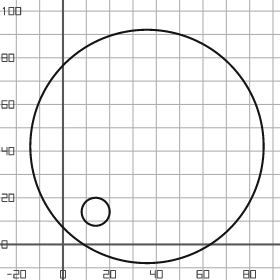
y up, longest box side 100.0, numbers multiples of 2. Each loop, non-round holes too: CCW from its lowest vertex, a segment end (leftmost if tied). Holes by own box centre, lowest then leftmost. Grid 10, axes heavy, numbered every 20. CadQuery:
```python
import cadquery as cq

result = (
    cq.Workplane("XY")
    .moveTo(36.0, 42.0)
    .circle(50.0)
    .moveTo(14.0, 14.0)
    .circle(6.0)
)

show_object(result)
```